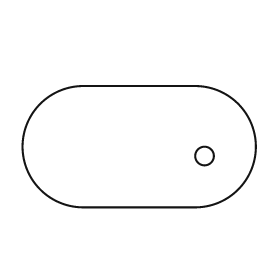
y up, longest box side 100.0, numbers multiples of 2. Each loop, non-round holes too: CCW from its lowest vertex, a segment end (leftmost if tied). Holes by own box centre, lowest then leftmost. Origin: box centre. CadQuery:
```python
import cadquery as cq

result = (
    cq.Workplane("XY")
    .moveTo(-24.0, -26.0)
    .lineTo(24.0, -26.0)
    .threePointArc((50.0, 0.0), (24.0, 26.0))
    .lineTo(-24.0, 26.0)
    .threePointArc((-50.0, 0.0), (-24.0, -26.0))
    .close()
    .moveTo(28.0, -4.0)
    .circle(4.0)
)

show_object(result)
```